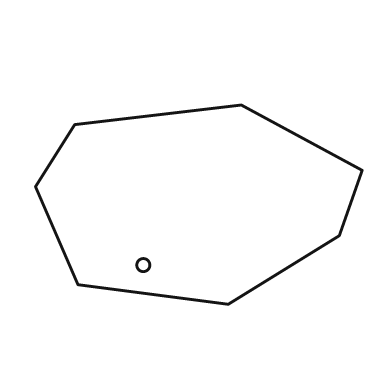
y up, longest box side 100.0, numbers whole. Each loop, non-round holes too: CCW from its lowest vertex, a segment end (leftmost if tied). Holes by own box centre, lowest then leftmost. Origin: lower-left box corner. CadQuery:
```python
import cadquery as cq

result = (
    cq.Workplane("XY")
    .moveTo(59.0, 0.0)
    .lineTo(93.0, 21.0)
    .lineTo(100.0, 41.0)
    .lineTo(63.0, 61.0)
    .lineTo(12.0, 55.0)
    .lineTo(0.0, 36.0)
    .lineTo(13.0, 6.0)
    .close()
    .moveTo(33.0, 12.0)
    .circle(2.0)
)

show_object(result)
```